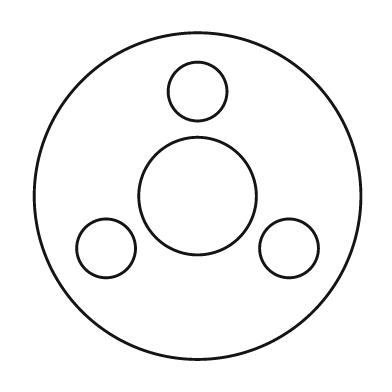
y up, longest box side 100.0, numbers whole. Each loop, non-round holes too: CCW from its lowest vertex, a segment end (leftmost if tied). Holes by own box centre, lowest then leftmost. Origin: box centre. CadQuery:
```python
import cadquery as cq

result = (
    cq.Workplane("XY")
    .moveTo(0.0, 0.0)
    .circle(50.0)
    .moveTo(-28.0, -16.0)
    .circle(9.0)
    .moveTo(28.0, -16.0)
    .circle(9.0)
    .moveTo(0.0, 0.0)
    .circle(18.0)
    .moveTo(0.0, 32.0)
    .circle(9.0)
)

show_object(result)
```